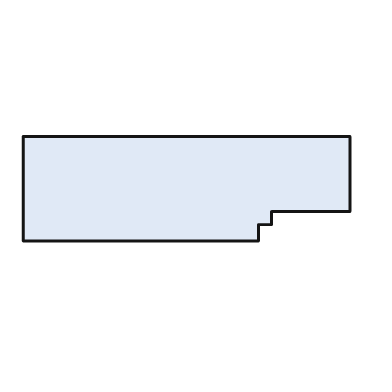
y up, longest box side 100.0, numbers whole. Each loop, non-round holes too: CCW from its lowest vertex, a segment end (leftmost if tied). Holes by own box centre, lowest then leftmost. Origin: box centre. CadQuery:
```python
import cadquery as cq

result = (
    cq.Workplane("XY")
    .moveTo(-50.0, -16.0)
    .lineTo(22.0, -16.0)
    .lineTo(22.0, -11.0)
    .lineTo(26.0, -11.0)
    .lineTo(26.0, -7.0)
    .lineTo(50.0, -7.0)
    .lineTo(50.0, 16.0)
    .lineTo(-50.0, 16.0)
    .close()
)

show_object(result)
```